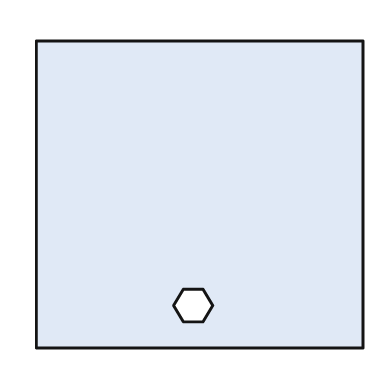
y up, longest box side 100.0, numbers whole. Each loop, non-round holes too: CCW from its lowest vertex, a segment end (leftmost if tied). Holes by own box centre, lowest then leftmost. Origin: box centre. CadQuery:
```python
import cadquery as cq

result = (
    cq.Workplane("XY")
    .moveTo(-50.0, -47.0)
    .lineTo(50.0, -47.0)
    .lineTo(50.0, 47.0)
    .lineTo(-50.0, 47.0)
    .close()
    .moveTo(-5.0, -39.0)
    .lineTo(1.0, -39.0)
    .lineTo(4.0, -34.0)
    .lineTo(1.0, -29.0)
    .lineTo(-5.0, -29.0)
    .lineTo(-8.0, -34.0)
    .close()
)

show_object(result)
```